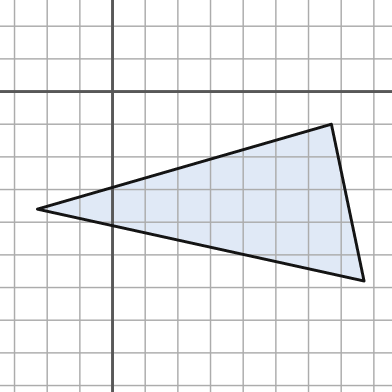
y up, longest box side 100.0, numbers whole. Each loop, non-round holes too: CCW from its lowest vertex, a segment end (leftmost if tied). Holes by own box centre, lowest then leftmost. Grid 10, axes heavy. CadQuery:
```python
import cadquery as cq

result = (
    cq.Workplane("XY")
    .moveTo(77.0, -58.0)
    .lineTo(67.0, -10.0)
    .lineTo(-23.0, -36.0)
    .close()
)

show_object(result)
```